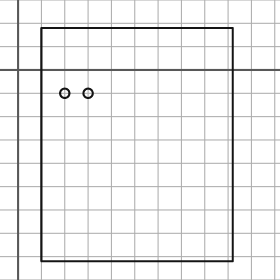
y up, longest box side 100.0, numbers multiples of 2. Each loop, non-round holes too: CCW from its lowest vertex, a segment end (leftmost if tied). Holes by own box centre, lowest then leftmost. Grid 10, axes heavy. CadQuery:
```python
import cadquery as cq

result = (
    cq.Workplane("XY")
    .moveTo(10.0, -82.0)
    .lineTo(92.0, -82.0)
    .lineTo(92.0, 18.0)
    .lineTo(10.0, 18.0)
    .close()
    .moveTo(20.0, -10.0)
    .circle(2.0)
    .moveTo(30.0, -10.0)
    .circle(2.0)
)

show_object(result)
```